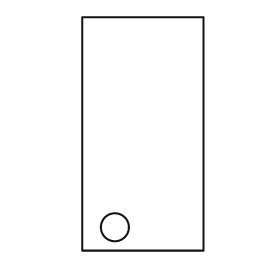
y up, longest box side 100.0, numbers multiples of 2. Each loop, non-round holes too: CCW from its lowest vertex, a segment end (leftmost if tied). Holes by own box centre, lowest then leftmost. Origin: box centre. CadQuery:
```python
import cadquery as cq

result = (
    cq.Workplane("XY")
    .moveTo(-26.0, -50.0)
    .lineTo(26.0, -50.0)
    .lineTo(26.0, 50.0)
    .lineTo(-26.0, 50.0)
    .close()
    .moveTo(-12.0, -40.0)
    .circle(6.0)
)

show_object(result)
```